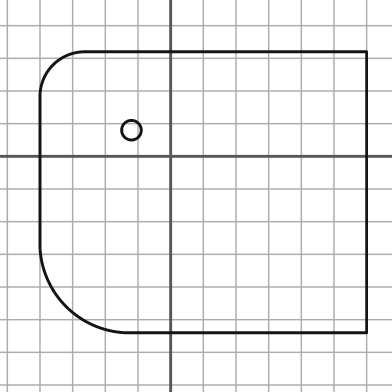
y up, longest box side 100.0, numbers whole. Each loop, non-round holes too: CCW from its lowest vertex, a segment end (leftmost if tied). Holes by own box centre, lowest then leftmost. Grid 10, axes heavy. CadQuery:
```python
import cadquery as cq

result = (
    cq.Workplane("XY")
    .moveTo(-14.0, -54.0)
    .lineTo(60.0, -54.0)
    .lineTo(60.0, 32.0)
    .lineTo(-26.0, 32.0)
    .threePointArc((-36.0, 28.0), (-40.0, 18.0))
    .lineTo(-40.0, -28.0)
    .threePointArc((-32.0, -46.0), (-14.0, -54.0))
    .close()
    .moveTo(-12.0, 8.0)
    .circle(3.0)
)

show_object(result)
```